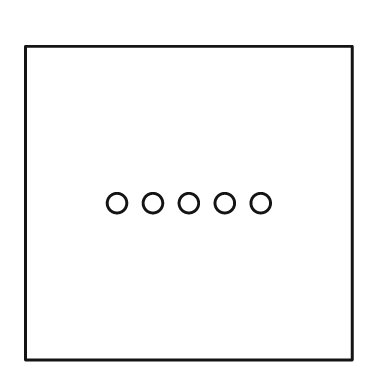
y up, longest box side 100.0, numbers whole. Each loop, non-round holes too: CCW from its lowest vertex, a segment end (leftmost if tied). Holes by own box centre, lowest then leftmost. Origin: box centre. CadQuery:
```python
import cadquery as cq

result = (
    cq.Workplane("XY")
    .moveTo(-50.0, -48.0)
    .lineTo(50.0, -48.0)
    .lineTo(50.0, 48.0)
    .lineTo(-50.0, 48.0)
    .close()
    .moveTo(-22.0, 0.0)
    .circle(3.0)
    .moveTo(-11.0, 0.0)
    .circle(3.0)
    .moveTo(0.0, 0.0)
    .circle(3.0)
    .moveTo(11.0, 0.0)
    .circle(3.0)
    .moveTo(22.0, 0.0)
    .circle(3.0)
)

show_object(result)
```